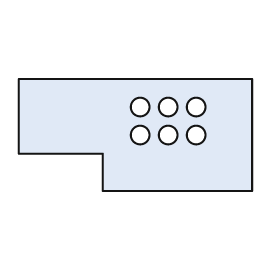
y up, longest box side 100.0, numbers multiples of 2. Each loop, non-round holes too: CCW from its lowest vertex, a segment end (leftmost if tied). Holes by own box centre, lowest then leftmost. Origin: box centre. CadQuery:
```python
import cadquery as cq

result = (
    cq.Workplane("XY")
    .moveTo(-14.0, -24.0)
    .lineTo(50.0, -24.0)
    .lineTo(50.0, 24.0)
    .lineTo(-50.0, 24.0)
    .lineTo(-50.0, -8.0)
    .lineTo(-14.0, -8.0)
    .close()
    .moveTo(2.0, 0.0)
    .circle(4.0)
    .moveTo(14.0, 0.0)
    .circle(4.0)
    .moveTo(26.0, 0.0)
    .circle(4.0)
    .moveTo(2.0, 12.0)
    .circle(4.0)
    .moveTo(14.0, 12.0)
    .circle(4.0)
    .moveTo(26.0, 12.0)
    .circle(4.0)
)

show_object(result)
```